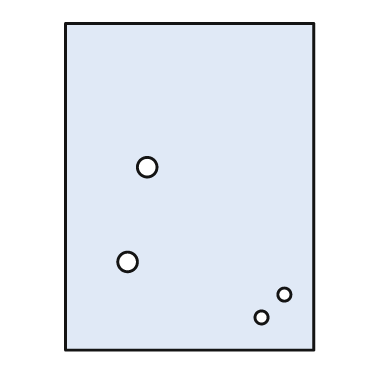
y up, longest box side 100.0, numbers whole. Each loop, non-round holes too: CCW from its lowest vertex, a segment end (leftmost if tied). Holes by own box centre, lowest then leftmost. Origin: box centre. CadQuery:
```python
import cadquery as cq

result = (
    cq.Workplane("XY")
    .moveTo(-38.0, -50.0)
    .lineTo(38.0, -50.0)
    .lineTo(38.0, 50.0)
    .lineTo(-38.0, 50.0)
    .close()
    .moveTo(22.0, -40.0)
    .circle(2.0)
    .moveTo(29.0, -33.0)
    .circle(2.0)
    .moveTo(-19.0, -23.0)
    .circle(3.0)
    .moveTo(-13.0, 6.0)
    .circle(3.0)
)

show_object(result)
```